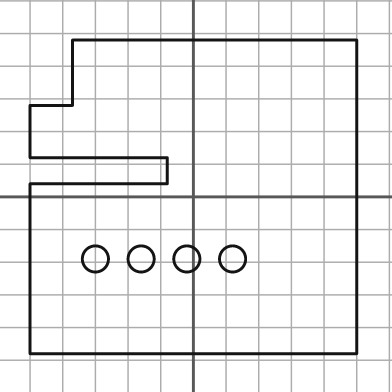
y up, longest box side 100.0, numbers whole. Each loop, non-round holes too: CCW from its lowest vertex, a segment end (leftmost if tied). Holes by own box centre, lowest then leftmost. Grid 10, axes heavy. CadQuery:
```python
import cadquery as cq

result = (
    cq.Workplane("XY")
    .moveTo(-50.0, -48.0)
    .lineTo(50.0, -48.0)
    .lineTo(50.0, 48.0)
    .lineTo(-37.0, 48.0)
    .lineTo(-37.0, 28.0)
    .lineTo(-50.0, 28.0)
    .lineTo(-50.0, 12.0)
    .lineTo(-8.0, 12.0)
    .lineTo(-8.0, 4.0)
    .lineTo(-50.0, 4.0)
    .close()
    .moveTo(-30.0, -19.0)
    .circle(4.0)
    .moveTo(-16.0, -19.0)
    .circle(4.0)
    .moveTo(-2.0, -19.0)
    .circle(4.0)
    .moveTo(12.0, -19.0)
    .circle(4.0)
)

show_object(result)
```